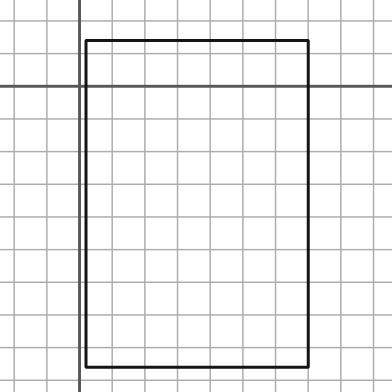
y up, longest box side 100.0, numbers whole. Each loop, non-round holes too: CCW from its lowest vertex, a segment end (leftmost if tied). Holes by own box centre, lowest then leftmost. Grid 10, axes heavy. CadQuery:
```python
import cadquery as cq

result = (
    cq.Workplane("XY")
    .moveTo(2.0, -86.0)
    .lineTo(70.0, -86.0)
    .lineTo(70.0, 14.0)
    .lineTo(2.0, 14.0)
    .close()
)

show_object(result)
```